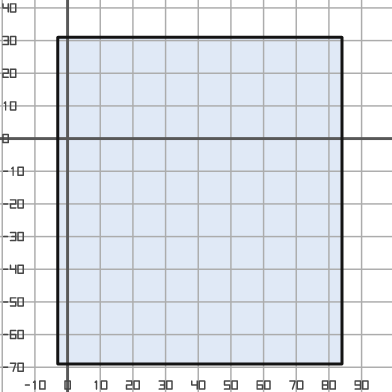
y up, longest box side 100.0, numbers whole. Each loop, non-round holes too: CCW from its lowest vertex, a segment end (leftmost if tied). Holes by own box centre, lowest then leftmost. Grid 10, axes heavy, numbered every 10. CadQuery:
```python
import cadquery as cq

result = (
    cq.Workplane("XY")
    .moveTo(-3.0, -69.0)
    .lineTo(84.0, -69.0)
    .lineTo(84.0, 31.0)
    .lineTo(-3.0, 31.0)
    .close()
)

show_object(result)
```